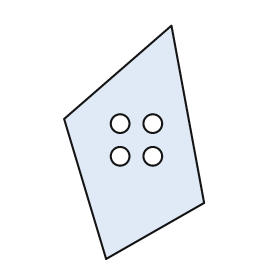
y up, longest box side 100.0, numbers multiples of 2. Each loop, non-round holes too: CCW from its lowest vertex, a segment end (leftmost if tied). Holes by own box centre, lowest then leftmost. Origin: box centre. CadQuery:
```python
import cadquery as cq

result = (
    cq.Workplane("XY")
    .moveTo(-12.0, -50.0)
    .lineTo(30.0, -26.0)
    .lineTo(16.0, 50.0)
    .lineTo(-30.0, 10.0)
    .close()
    .moveTo(-6.0, -6.0)
    .circle(4.0)
    .moveTo(8.0, -6.0)
    .circle(4.0)
    .moveTo(-6.0, 8.0)
    .circle(4.0)
    .moveTo(8.0, 8.0)
    .circle(4.0)
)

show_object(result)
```